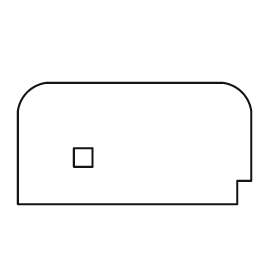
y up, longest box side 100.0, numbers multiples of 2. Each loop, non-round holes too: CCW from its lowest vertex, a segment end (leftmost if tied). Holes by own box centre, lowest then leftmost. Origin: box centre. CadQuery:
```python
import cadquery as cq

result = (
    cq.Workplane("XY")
    .moveTo(-50.0, -26.0)
    .lineTo(44.0, -26.0)
    .lineTo(44.0, -16.0)
    .lineTo(50.0, -16.0)
    .lineTo(50.0, 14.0)
    .threePointArc((46.0, 22.0), (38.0, 26.0))
    .lineTo(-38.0, 26.0)
    .threePointArc((-46.0, 22.0), (-50.0, 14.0))
    .close()
    .moveTo(-26.0, -10.0)
    .lineTo(-18.0, -10.0)
    .lineTo(-18.0, -2.0)
    .lineTo(-26.0, -2.0)
    .close()
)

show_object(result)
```